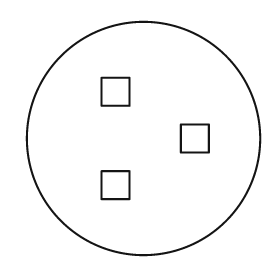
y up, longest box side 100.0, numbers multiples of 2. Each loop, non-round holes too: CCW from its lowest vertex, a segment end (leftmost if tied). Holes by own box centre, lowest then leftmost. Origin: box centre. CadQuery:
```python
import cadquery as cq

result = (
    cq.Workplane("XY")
    .moveTo(0.0, 0.0)
    .circle(50.0)
    .moveTo(-18.0, -26.0)
    .lineTo(-6.0, -26.0)
    .lineTo(-6.0, -14.0)
    .lineTo(-18.0, -14.0)
    .close()
    .moveTo(16.0, -6.0)
    .lineTo(28.0, -6.0)
    .lineTo(28.0, 6.0)
    .lineTo(16.0, 6.0)
    .close()
    .moveTo(-18.0, 14.0)
    .lineTo(-6.0, 14.0)
    .lineTo(-6.0, 26.0)
    .lineTo(-18.0, 26.0)
    .close()
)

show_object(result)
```